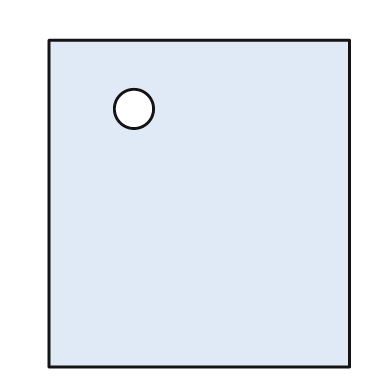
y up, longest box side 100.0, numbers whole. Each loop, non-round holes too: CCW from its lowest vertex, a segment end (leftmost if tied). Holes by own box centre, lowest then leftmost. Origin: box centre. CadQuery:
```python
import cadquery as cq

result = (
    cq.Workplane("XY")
    .moveTo(-46.0, -50.0)
    .lineTo(46.0, -50.0)
    .lineTo(46.0, 50.0)
    .lineTo(-46.0, 50.0)
    .close()
    .moveTo(-20.0, 29.0)
    .circle(6.0)
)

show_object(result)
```